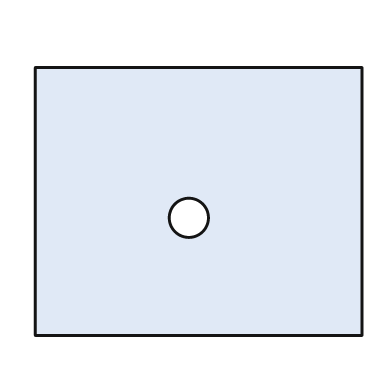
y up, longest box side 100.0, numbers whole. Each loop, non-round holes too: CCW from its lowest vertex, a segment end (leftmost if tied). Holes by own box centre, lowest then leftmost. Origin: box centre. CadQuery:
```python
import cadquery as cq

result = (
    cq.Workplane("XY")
    .moveTo(-50.0, -41.0)
    .lineTo(50.0, -41.0)
    .lineTo(50.0, 41.0)
    .lineTo(-50.0, 41.0)
    .close()
    .moveTo(-3.0, -5.0)
    .circle(6.0)
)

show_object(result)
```